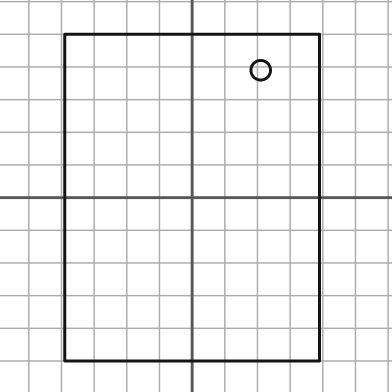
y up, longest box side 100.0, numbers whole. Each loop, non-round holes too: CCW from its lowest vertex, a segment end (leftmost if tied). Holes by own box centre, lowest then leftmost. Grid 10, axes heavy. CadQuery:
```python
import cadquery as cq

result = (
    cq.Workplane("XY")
    .moveTo(-39.0, -50.0)
    .lineTo(39.0, -50.0)
    .lineTo(39.0, 50.0)
    .lineTo(-39.0, 50.0)
    .close()
    .moveTo(21.0, 39.0)
    .circle(3.0)
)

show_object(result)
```